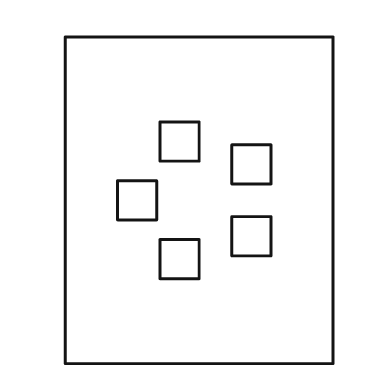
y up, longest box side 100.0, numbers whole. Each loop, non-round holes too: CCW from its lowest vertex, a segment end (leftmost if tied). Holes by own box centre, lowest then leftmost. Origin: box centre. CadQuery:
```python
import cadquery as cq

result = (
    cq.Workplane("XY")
    .moveTo(-41.0, -50.0)
    .lineTo(41.0, -50.0)
    .lineTo(41.0, 50.0)
    .lineTo(-41.0, 50.0)
    .close()
    .moveTo(-12.0, -24.0)
    .lineTo(0.0, -24.0)
    .lineTo(0.0, -12.0)
    .lineTo(-12.0, -12.0)
    .close()
    .moveTo(10.0, -17.0)
    .lineTo(22.0, -17.0)
    .lineTo(22.0, -5.0)
    .lineTo(10.0, -5.0)
    .close()
    .moveTo(-25.0, -6.0)
    .lineTo(-13.0, -6.0)
    .lineTo(-13.0, 6.0)
    .lineTo(-25.0, 6.0)
    .close()
    .moveTo(10.0, 5.0)
    .lineTo(22.0, 5.0)
    .lineTo(22.0, 17.0)
    .lineTo(10.0, 17.0)
    .close()
    .moveTo(-12.0, 12.0)
    .lineTo(0.0, 12.0)
    .lineTo(0.0, 24.0)
    .lineTo(-12.0, 24.0)
    .close()
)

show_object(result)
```